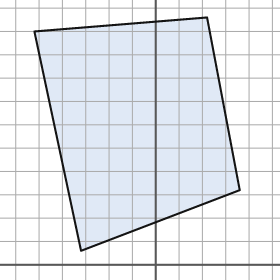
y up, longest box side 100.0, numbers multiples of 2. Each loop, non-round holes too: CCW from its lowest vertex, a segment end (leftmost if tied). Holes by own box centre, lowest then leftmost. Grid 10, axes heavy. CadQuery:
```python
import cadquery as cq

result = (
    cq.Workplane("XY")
    .moveTo(-32.0, 6.0)
    .lineTo(36.0, 32.0)
    .lineTo(22.0, 106.0)
    .lineTo(-52.0, 100.0)
    .close()
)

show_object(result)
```